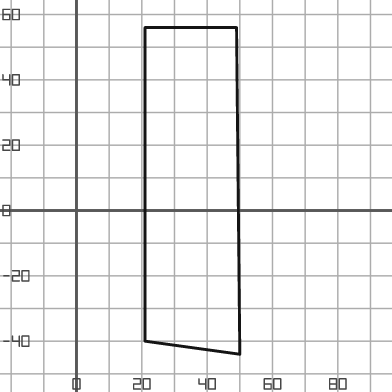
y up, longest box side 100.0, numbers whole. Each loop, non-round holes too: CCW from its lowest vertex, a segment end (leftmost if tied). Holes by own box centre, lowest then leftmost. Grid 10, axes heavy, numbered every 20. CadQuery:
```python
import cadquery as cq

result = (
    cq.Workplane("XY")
    .moveTo(50.0, -44.0)
    .lineTo(49.0, 56.0)
    .lineTo(21.0, 56.0)
    .lineTo(21.0, -40.0)
    .close()
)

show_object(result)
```